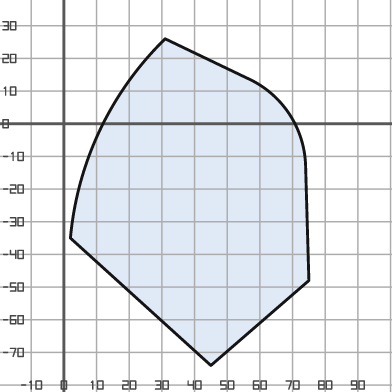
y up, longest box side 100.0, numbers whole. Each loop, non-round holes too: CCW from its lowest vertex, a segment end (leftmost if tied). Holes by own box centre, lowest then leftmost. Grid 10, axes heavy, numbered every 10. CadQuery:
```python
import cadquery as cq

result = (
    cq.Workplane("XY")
    .moveTo(45.0, -74.0)
    .lineTo(75.0, -48.0)
    .lineTo(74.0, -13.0)
    .threePointArc((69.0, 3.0), (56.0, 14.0))
    .lineTo(31.0, 26.0)
    .threePointArc((11.0, -2.0), (2.0, -35.0))
    .close()
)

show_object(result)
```